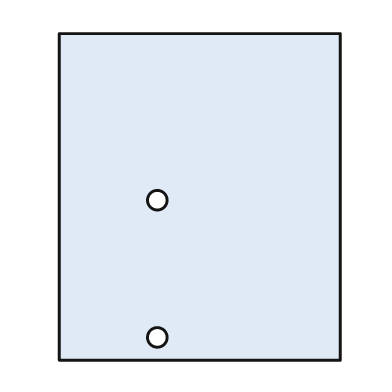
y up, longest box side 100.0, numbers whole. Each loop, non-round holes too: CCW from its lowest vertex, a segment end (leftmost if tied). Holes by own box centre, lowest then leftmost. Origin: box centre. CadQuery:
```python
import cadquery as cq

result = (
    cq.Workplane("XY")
    .moveTo(-43.0, -50.0)
    .lineTo(43.0, -50.0)
    .lineTo(43.0, 50.0)
    .lineTo(-43.0, 50.0)
    .close()
    .moveTo(-13.0, -43.0)
    .circle(3.0)
    .moveTo(-13.0, -1.0)
    .circle(3.0)
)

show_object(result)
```